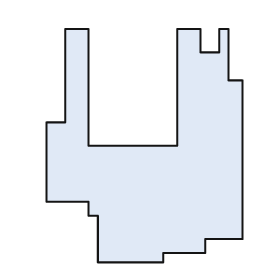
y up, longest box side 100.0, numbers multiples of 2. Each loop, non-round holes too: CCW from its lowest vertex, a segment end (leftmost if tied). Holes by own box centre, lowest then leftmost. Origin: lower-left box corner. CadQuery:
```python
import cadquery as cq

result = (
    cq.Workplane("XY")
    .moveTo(22.0, 0.0)
    .lineTo(50.0, 0.0)
    .lineTo(50.0, 4.0)
    .lineTo(68.0, 4.0)
    .lineTo(68.0, 10.0)
    .lineTo(84.0, 10.0)
    .lineTo(84.0, 78.0)
    .lineTo(78.0, 78.0)
    .lineTo(78.0, 100.0)
    .lineTo(74.0, 100.0)
    .lineTo(74.0, 90.0)
    .lineTo(66.0, 90.0)
    .lineTo(66.0, 100.0)
    .lineTo(56.0, 100.0)
    .lineTo(56.0, 50.0)
    .lineTo(18.0, 50.0)
    .lineTo(18.0, 100.0)
    .lineTo(8.0, 100.0)
    .lineTo(8.0, 60.0)
    .lineTo(0.0, 60.0)
    .lineTo(0.0, 26.0)
    .lineTo(18.0, 26.0)
    .lineTo(18.0, 20.0)
    .lineTo(22.0, 20.0)
    .close()
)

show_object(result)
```